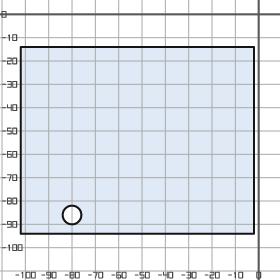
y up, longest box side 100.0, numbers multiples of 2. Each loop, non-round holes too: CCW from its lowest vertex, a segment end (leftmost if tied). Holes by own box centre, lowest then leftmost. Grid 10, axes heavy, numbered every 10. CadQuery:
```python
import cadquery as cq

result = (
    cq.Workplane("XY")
    .moveTo(-102.0, -94.0)
    .lineTo(-2.0, -94.0)
    .lineTo(-2.0, -14.0)
    .lineTo(-102.0, -14.0)
    .close()
    .moveTo(-80.0, -86.0)
    .circle(4.0)
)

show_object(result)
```